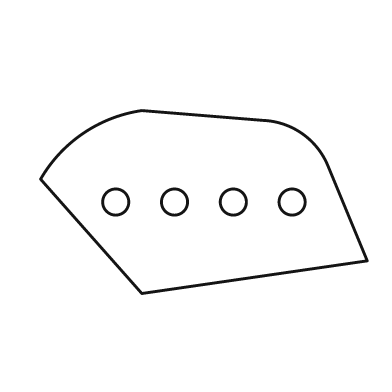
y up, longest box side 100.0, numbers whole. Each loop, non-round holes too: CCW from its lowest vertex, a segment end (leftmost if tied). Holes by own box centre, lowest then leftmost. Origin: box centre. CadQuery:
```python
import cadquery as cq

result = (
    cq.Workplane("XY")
    .moveTo(-19.0, -28.0)
    .lineTo(50.0, -18.0)
    .lineTo(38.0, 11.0)
    .threePointArc((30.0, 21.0), (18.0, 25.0))
    .lineTo(-19.0, 28.0)
    .threePointArc((-37.0, 21.0), (-50.0, 7.0))
    .close()
    .moveTo(-27.0, 0.0)
    .circle(4.0)
    .moveTo(-9.0, 0.0)
    .circle(4.0)
    .moveTo(9.0, 0.0)
    .circle(4.0)
    .moveTo(27.0, 0.0)
    .circle(4.0)
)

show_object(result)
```